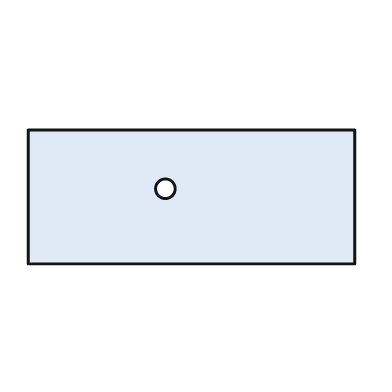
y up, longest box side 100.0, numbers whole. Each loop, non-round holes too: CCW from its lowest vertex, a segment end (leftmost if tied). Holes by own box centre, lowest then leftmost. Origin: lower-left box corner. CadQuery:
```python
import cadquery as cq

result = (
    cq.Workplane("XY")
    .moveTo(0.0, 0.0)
    .lineTo(100.0, 0.0)
    .lineTo(100.0, 41.0)
    .lineTo(0.0, 41.0)
    .close()
    .moveTo(42.0, 23.0)
    .circle(3.0)
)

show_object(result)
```